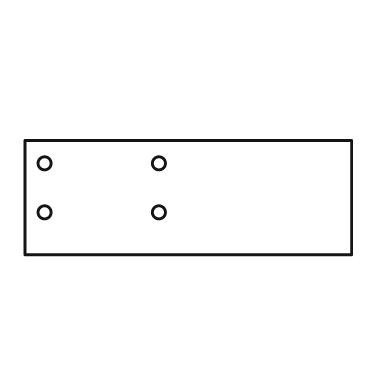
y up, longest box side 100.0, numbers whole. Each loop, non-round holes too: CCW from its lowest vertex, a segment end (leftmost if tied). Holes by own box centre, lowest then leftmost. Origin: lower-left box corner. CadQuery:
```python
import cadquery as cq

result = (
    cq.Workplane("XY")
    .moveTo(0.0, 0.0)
    .lineTo(100.0, 0.0)
    .lineTo(100.0, 35.0)
    .lineTo(0.0, 35.0)
    .close()
    .moveTo(6.0, 13.0)
    .circle(2.0)
    .moveTo(41.0, 13.0)
    .circle(2.0)
    .moveTo(6.0, 28.0)
    .circle(2.0)
    .moveTo(41.0, 28.0)
    .circle(2.0)
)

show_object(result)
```